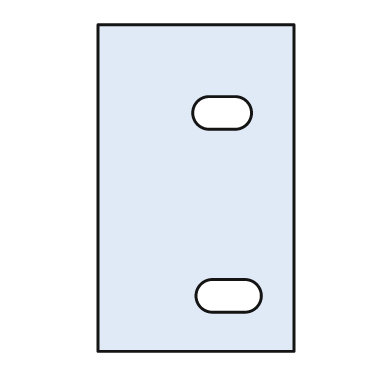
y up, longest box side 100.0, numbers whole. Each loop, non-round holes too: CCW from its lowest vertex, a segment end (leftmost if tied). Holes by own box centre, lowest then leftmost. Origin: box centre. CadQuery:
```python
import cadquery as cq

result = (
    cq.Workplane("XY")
    .moveTo(-30.0, -50.0)
    .lineTo(30.0, -50.0)
    .lineTo(30.0, 50.0)
    .lineTo(-30.0, 50.0)
    .close()
    .moveTo(5.0, -38.0)
    .lineTo(15.0, -38.0)
    .threePointArc((20.0, -33.0), (15.0, -28.0))
    .lineTo(5.0, -28.0)
    .threePointArc((0.0, -33.0), (5.0, -38.0))
    .close()
    .moveTo(4.0, 18.0)
    .lineTo(12.0, 18.0)
    .threePointArc((17.0, 23.0), (12.0, 28.0))
    .lineTo(4.0, 28.0)
    .threePointArc((-1.0, 23.0), (4.0, 18.0))
    .close()
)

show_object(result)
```